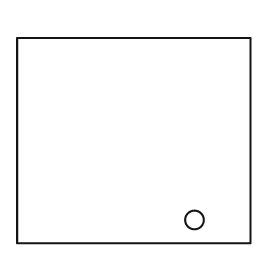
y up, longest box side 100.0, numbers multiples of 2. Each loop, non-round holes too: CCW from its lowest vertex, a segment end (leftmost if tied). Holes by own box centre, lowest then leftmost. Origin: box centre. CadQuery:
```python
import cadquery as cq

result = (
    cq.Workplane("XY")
    .moveTo(-50.0, -44.0)
    .lineTo(50.0, -44.0)
    .lineTo(50.0, 44.0)
    .lineTo(-50.0, 44.0)
    .close()
    .moveTo(26.0, -34.0)
    .circle(4.0)
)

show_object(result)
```